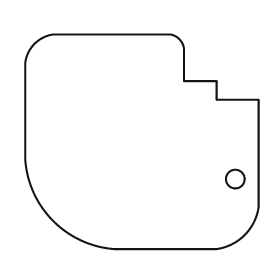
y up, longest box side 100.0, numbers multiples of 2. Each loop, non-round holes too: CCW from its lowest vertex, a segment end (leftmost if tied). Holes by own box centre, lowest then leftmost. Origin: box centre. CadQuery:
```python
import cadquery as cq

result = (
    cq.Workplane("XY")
    .moveTo(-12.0, -46.0)
    .lineTo(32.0, -46.0)
    .threePointArc((44.0, -40.0), (50.0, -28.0))
    .lineTo(50.0, 18.0)
    .lineTo(32.0, 18.0)
    .lineTo(32.0, 26.0)
    .lineTo(18.0, 26.0)
    .lineTo(18.0, 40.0)
    .threePointArc((16.0, 44.0), (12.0, 46.0))
    .lineTo(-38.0, 46.0)
    .threePointArc((-46.0, 42.0), (-50.0, 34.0))
    .lineTo(-50.0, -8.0)
    .threePointArc((-38.0, -34.0), (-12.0, -46.0))
    .close()
    .moveTo(40.0, -16.0)
    .circle(4.0)
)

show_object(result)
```